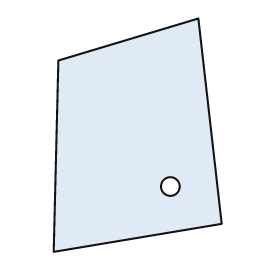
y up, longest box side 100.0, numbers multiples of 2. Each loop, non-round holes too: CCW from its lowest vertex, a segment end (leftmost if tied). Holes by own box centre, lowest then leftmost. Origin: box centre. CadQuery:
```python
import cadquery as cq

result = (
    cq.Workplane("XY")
    .moveTo(-36.0, -50.0)
    .lineTo(36.0, -38.0)
    .lineTo(26.0, 50.0)
    .lineTo(-34.0, 32.0)
    .close()
    .moveTo(14.0, -22.0)
    .circle(4.0)
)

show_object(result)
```